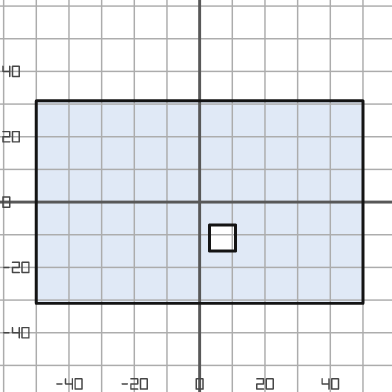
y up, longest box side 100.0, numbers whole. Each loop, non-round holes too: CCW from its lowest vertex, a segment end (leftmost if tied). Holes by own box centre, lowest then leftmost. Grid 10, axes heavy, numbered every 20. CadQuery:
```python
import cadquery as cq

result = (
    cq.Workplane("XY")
    .moveTo(-50.0, -31.0)
    .lineTo(50.0, -31.0)
    .lineTo(50.0, 31.0)
    .lineTo(-50.0, 31.0)
    .close()
    .moveTo(3.0, -15.0)
    .lineTo(11.0, -15.0)
    .lineTo(11.0, -7.0)
    .lineTo(3.0, -7.0)
    .close()
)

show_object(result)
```